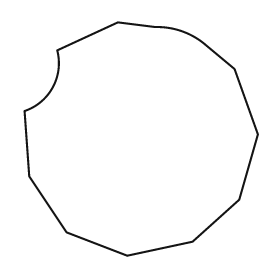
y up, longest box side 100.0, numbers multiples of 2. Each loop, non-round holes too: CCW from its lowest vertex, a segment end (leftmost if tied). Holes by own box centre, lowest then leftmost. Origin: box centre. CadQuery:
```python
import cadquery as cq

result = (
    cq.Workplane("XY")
    .moveTo(-6.0, -50.0)
    .lineTo(22.0, -44.0)
    .lineTo(42.0, -26.0)
    .lineTo(50.0, 2.0)
    .lineTo(40.0, 30.0)
    .lineTo(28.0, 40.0)
    .threePointArc((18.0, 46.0), (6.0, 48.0))
    .lineTo(-10.0, 50.0)
    .lineTo(-36.0, 38.0)
    .threePointArc((-38.0, 22.0), (-50.0, 12.0))
    .lineTo(-48.0, -16.0)
    .lineTo(-32.0, -40.0)
    .close()
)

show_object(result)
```